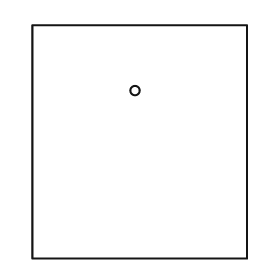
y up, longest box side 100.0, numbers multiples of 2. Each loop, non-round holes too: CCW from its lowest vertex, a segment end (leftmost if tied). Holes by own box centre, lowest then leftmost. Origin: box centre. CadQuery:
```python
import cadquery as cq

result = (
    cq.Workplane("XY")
    .moveTo(-46.0, -50.0)
    .lineTo(46.0, -50.0)
    .lineTo(46.0, 50.0)
    .lineTo(-46.0, 50.0)
    .close()
    .moveTo(-2.0, 22.0)
    .circle(2.0)
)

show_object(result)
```